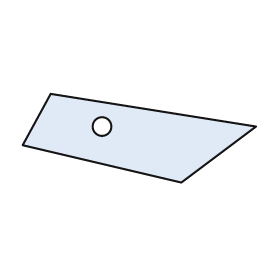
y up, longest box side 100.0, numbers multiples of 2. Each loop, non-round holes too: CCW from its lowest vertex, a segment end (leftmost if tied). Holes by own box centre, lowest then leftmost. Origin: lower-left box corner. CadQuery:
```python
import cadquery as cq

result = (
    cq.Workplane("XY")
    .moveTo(68.0, 0.0)
    .lineTo(100.0, 24.0)
    .lineTo(12.0, 38.0)
    .lineTo(0.0, 16.0)
    .close()
    .moveTo(34.0, 24.0)
    .circle(4.0)
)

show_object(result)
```